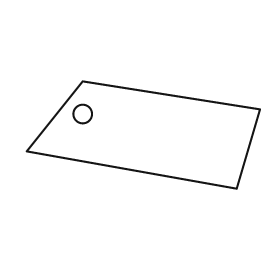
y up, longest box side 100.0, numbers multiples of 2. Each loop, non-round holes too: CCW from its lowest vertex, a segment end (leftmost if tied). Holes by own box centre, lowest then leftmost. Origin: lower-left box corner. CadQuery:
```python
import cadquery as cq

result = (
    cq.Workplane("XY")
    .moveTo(90.0, 0.0)
    .lineTo(100.0, 34.0)
    .lineTo(24.0, 46.0)
    .lineTo(0.0, 16.0)
    .close()
    .moveTo(24.0, 32.0)
    .circle(4.0)
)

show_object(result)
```